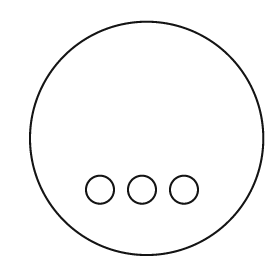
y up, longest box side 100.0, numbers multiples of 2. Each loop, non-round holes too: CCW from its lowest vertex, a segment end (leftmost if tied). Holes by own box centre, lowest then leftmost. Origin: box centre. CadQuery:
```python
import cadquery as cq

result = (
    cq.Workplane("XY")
    .moveTo(0.0, 0.0)
    .circle(50.0)
    .moveTo(-20.0, -22.0)
    .circle(6.0)
    .moveTo(-2.0, -22.0)
    .circle(6.0)
    .moveTo(16.0, -22.0)
    .circle(6.0)
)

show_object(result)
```